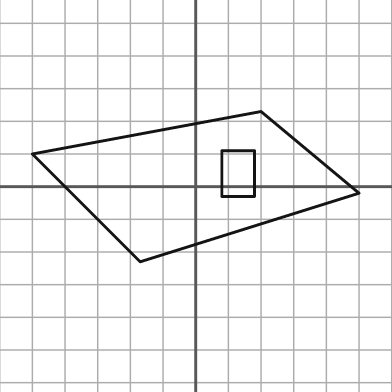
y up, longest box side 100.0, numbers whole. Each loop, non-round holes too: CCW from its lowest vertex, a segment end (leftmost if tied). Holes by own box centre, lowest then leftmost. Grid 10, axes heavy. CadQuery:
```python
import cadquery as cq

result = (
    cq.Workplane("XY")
    .moveTo(-17.0, -23.0)
    .lineTo(50.0, -2.0)
    .lineTo(20.0, 23.0)
    .lineTo(-50.0, 10.0)
    .close()
    .moveTo(8.0, -3.0)
    .lineTo(18.0, -3.0)
    .lineTo(18.0, 11.0)
    .lineTo(8.0, 11.0)
    .close()
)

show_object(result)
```